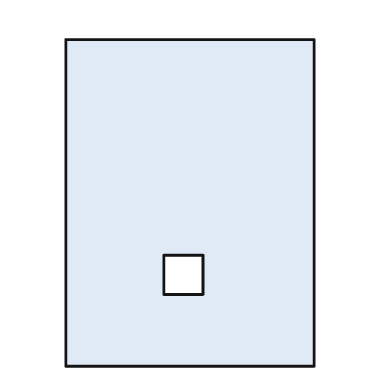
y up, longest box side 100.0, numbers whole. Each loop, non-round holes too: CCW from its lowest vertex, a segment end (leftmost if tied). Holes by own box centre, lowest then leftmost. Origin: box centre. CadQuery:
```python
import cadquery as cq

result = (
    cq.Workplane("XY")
    .moveTo(-38.0, -50.0)
    .lineTo(38.0, -50.0)
    .lineTo(38.0, 50.0)
    .lineTo(-38.0, 50.0)
    .close()
    .moveTo(-8.0, -28.0)
    .lineTo(4.0, -28.0)
    .lineTo(4.0, -16.0)
    .lineTo(-8.0, -16.0)
    .close()
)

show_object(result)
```